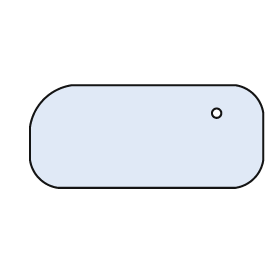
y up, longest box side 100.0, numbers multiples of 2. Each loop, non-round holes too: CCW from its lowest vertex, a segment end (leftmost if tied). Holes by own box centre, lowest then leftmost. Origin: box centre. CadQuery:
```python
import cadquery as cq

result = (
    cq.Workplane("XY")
    .moveTo(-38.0, -22.0)
    .lineTo(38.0, -22.0)
    .threePointArc((46.0, -18.0), (50.0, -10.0))
    .lineTo(50.0, 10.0)
    .threePointArc((46.0, 18.0), (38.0, 22.0))
    .lineTo(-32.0, 22.0)
    .threePointArc((-44.0, 16.0), (-50.0, 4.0))
    .lineTo(-50.0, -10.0)
    .threePointArc((-46.0, -18.0), (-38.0, -22.0))
    .close()
    .moveTo(30.0, 10.0)
    .circle(2.0)
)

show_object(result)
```